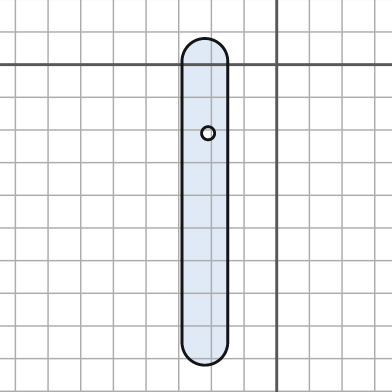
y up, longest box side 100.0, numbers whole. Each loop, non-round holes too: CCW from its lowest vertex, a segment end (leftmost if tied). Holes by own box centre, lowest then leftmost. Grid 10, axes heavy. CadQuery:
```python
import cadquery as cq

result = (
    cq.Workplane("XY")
    .moveTo(-29.0, -85.0)
    .threePointArc((-22.0, -92.0), (-15.0, -85.0))
    .lineTo(-15.0, 1.0)
    .threePointArc((-22.0, 8.0), (-29.0, 1.0))
    .close()
    .moveTo(-21.0, -21.0)
    .circle(2.0)
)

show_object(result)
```